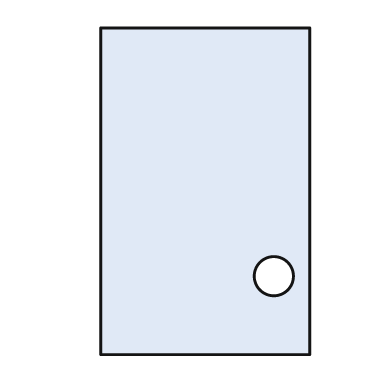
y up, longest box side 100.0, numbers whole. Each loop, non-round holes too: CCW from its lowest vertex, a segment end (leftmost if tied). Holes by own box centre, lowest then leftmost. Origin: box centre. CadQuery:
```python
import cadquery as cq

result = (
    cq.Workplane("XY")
    .moveTo(-32.0, -50.0)
    .lineTo(32.0, -50.0)
    .lineTo(32.0, 50.0)
    .lineTo(-32.0, 50.0)
    .close()
    .moveTo(21.0, -26.0)
    .circle(6.0)
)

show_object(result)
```